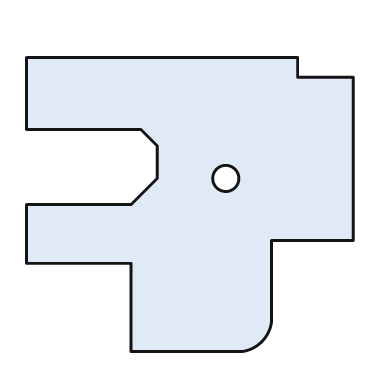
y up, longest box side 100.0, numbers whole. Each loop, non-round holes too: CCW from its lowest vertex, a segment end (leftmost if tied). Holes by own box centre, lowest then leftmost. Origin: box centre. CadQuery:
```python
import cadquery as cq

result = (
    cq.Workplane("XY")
    .moveTo(-18.0, -45.0)
    .lineTo(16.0, -45.0)
    .threePointArc((22.0, -42.0), (25.0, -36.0))
    .lineTo(25.0, -11.0)
    .lineTo(50.0, -11.0)
    .lineTo(50.0, 39.0)
    .lineTo(33.0, 39.0)
    .lineTo(33.0, 45.0)
    .lineTo(-50.0, 45.0)
    .lineTo(-50.0, 23.0)
    .lineTo(-15.0, 23.0)
    .lineTo(-10.0, 18.0)
    .lineTo(-10.0, 8.0)
    .lineTo(-18.0, 0.0)
    .lineTo(-50.0, 0.0)
    .lineTo(-50.0, -18.0)
    .lineTo(-18.0, -18.0)
    .close()
    .moveTo(11.0, 8.0)
    .circle(4.0)
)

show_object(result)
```